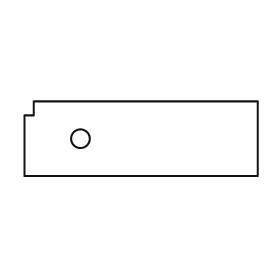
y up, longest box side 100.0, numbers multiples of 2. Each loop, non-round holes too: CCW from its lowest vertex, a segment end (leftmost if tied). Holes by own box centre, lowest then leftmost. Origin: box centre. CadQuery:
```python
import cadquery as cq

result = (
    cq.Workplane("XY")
    .moveTo(-50.0, -16.0)
    .lineTo(50.0, -16.0)
    .lineTo(50.0, 16.0)
    .lineTo(-46.0, 16.0)
    .lineTo(-46.0, 10.0)
    .lineTo(-50.0, 10.0)
    .close()
    .moveTo(-26.0, 0.0)
    .circle(4.0)
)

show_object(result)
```